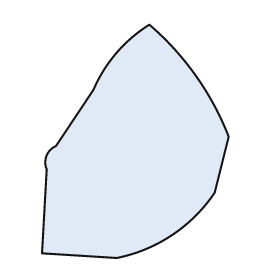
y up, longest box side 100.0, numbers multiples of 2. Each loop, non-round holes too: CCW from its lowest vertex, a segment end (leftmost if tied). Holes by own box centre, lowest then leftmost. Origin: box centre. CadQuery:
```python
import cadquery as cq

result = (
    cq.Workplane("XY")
    .moveTo(-8.0, -50.0)
    .threePointArc((16.0, -40.0), (34.0, -22.0))
    .lineTo(40.0, 2.0)
    .threePointArc((26.0, 28.0), (6.0, 50.0))
    .threePointArc((-8.0, 38.0), (-18.0, 22.0))
    .lineTo(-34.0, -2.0)
    .threePointArc((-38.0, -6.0), (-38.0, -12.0))
    .lineTo(-40.0, -48.0)
    .close()
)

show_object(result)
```